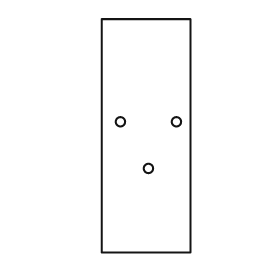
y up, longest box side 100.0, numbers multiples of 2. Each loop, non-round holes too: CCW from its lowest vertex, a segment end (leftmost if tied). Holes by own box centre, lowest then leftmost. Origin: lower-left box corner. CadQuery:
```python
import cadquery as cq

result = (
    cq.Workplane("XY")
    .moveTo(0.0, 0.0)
    .lineTo(38.0, 0.0)
    .lineTo(38.0, 100.0)
    .lineTo(0.0, 100.0)
    .close()
    .moveTo(20.0, 36.0)
    .circle(2.0)
    .moveTo(8.0, 56.0)
    .circle(2.0)
    .moveTo(32.0, 56.0)
    .circle(2.0)
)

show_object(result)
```